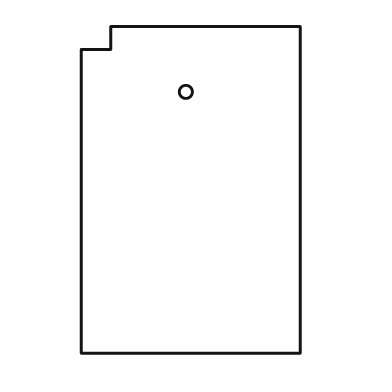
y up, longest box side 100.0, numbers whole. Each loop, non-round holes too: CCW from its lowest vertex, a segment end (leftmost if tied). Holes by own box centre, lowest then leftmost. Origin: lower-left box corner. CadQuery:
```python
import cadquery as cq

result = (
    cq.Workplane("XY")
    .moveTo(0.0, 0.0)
    .lineTo(67.0, 0.0)
    .lineTo(67.0, 100.0)
    .lineTo(9.0, 100.0)
    .lineTo(9.0, 93.0)
    .lineTo(0.0, 93.0)
    .close()
    .moveTo(32.0, 80.0)
    .circle(2.0)
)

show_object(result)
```